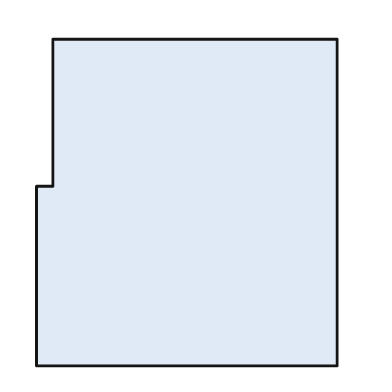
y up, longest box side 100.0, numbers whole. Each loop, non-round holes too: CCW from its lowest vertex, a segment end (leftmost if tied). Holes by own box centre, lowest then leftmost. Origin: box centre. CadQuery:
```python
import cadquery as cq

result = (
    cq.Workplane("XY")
    .moveTo(-46.0, -50.0)
    .lineTo(46.0, -50.0)
    .lineTo(46.0, 50.0)
    .lineTo(-41.0, 50.0)
    .lineTo(-41.0, 5.0)
    .lineTo(-46.0, 5.0)
    .close()
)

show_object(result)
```